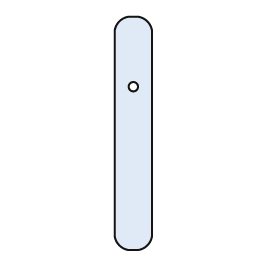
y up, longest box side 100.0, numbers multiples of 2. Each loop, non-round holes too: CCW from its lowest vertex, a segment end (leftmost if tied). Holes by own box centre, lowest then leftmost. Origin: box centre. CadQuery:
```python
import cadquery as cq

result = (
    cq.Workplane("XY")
    .moveTo(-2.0, -50.0)
    .lineTo(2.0, -50.0)
    .threePointArc((6.0, -48.0), (8.0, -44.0))
    .lineTo(8.0, 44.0)
    .threePointArc((6.0, 48.0), (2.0, 50.0))
    .lineTo(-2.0, 50.0)
    .threePointArc((-6.0, 48.0), (-8.0, 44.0))
    .lineTo(-8.0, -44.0)
    .threePointArc((-6.0, -48.0), (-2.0, -50.0))
    .close()
    .moveTo(0.0, 20.0)
    .circle(2.0)
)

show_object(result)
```